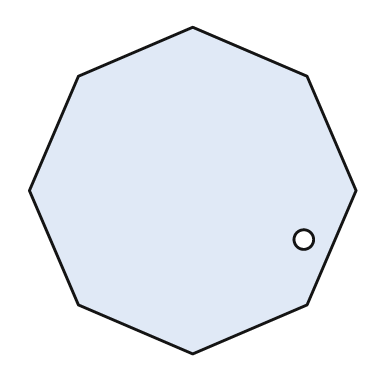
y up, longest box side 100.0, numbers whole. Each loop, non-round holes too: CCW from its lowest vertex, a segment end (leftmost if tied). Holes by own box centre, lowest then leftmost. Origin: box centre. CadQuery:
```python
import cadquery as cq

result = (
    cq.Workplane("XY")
    .moveTo(0.0, -50.0)
    .lineTo(35.0, -35.0)
    .lineTo(50.0, 0.0)
    .lineTo(35.0, 35.0)
    .lineTo(0.0, 50.0)
    .lineTo(-35.0, 35.0)
    .lineTo(-50.0, 0.0)
    .lineTo(-35.0, -35.0)
    .close()
    .moveTo(34.0, -15.0)
    .circle(3.0)
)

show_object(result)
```